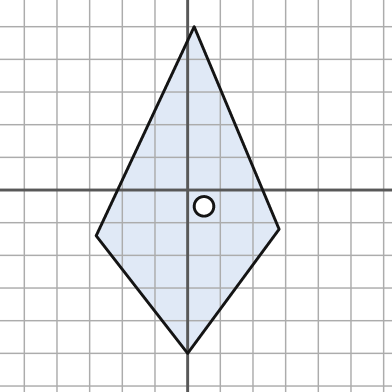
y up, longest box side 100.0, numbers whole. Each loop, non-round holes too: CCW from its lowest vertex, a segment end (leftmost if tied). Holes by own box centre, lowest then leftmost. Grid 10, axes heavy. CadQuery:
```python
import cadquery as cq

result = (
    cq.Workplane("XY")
    .moveTo(0.0, -50.0)
    .lineTo(28.0, -12.0)
    .lineTo(2.0, 50.0)
    .lineTo(-28.0, -14.0)
    .close()
    .moveTo(5.0, -5.0)
    .circle(3.0)
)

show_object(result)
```